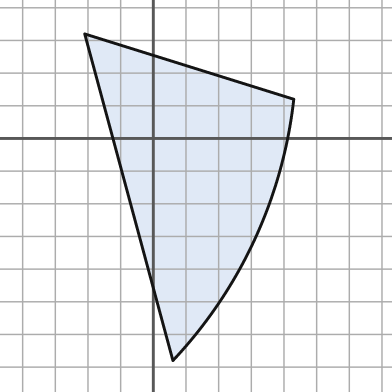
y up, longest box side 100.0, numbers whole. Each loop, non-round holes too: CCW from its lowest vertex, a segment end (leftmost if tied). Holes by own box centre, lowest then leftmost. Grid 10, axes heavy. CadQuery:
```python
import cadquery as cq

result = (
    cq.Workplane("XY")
    .moveTo(6.0, -68.0)
    .threePointArc((31.0, -31.0), (43.0, 12.0))
    .lineTo(-21.0, 32.0)
    .close()
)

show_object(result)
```